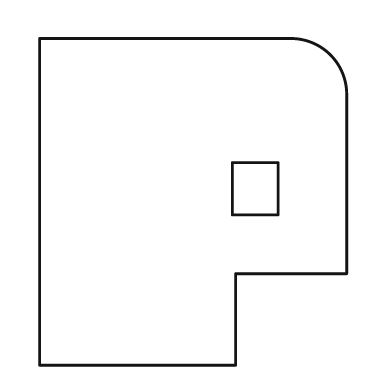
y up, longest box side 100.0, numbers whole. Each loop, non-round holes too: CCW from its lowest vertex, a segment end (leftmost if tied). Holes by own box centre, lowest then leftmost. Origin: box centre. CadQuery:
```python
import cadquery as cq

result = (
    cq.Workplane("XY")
    .moveTo(-47.0, -50.0)
    .lineTo(13.0, -50.0)
    .lineTo(13.0, -22.0)
    .lineTo(47.0, -22.0)
    .lineTo(47.0, 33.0)
    .threePointArc((42.0, 45.0), (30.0, 50.0))
    .lineTo(-47.0, 50.0)
    .close()
    .moveTo(12.0, -4.0)
    .lineTo(26.0, -4.0)
    .lineTo(26.0, 12.0)
    .lineTo(12.0, 12.0)
    .close()
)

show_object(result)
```